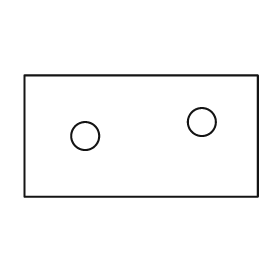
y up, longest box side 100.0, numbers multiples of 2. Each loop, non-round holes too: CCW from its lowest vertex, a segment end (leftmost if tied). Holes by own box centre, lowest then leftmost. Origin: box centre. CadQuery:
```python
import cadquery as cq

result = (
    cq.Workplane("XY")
    .moveTo(-50.0, -26.0)
    .lineTo(50.0, -26.0)
    .lineTo(50.0, 26.0)
    .lineTo(-50.0, 26.0)
    .close()
    .moveTo(-24.0, 0.0)
    .circle(6.0)
    .moveTo(26.0, 6.0)
    .circle(6.0)
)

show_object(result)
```